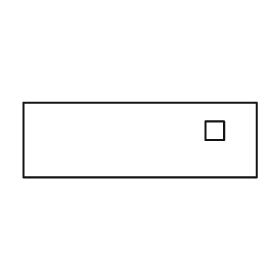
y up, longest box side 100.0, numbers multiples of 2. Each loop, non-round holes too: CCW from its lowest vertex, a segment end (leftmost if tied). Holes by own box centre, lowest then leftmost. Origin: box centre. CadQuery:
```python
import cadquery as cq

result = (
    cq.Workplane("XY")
    .moveTo(-50.0, -16.0)
    .lineTo(50.0, -16.0)
    .lineTo(50.0, 16.0)
    .lineTo(-50.0, 16.0)
    .close()
    .moveTo(28.0, 0.0)
    .lineTo(36.0, 0.0)
    .lineTo(36.0, 8.0)
    .lineTo(28.0, 8.0)
    .close()
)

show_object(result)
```